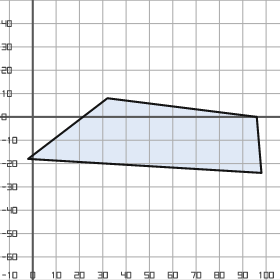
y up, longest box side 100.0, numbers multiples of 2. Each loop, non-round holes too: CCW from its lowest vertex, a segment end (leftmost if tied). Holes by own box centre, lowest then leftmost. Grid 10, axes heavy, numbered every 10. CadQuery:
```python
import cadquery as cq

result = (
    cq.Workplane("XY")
    .moveTo(98.0, -24.0)
    .lineTo(96.0, 0.0)
    .lineTo(32.0, 8.0)
    .lineTo(-2.0, -18.0)
    .close()
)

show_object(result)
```